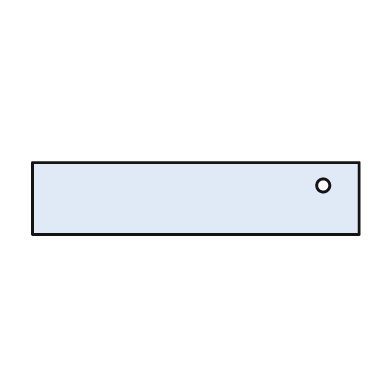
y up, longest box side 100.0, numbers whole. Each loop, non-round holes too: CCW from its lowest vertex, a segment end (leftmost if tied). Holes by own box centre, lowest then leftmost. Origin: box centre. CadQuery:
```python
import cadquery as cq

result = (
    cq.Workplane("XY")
    .moveTo(-50.0, -11.0)
    .lineTo(50.0, -11.0)
    .lineTo(50.0, 11.0)
    .lineTo(-50.0, 11.0)
    .close()
    .moveTo(39.0, 4.0)
    .circle(2.0)
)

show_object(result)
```